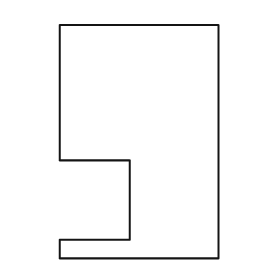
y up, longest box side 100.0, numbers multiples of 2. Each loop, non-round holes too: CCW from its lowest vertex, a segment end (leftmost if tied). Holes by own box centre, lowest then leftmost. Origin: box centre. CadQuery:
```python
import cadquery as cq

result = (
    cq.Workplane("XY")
    .moveTo(-34.0, -50.0)
    .lineTo(34.0, -50.0)
    .lineTo(34.0, 50.0)
    .lineTo(-34.0, 50.0)
    .lineTo(-34.0, -8.0)
    .lineTo(-4.0, -8.0)
    .lineTo(-4.0, -42.0)
    .lineTo(-34.0, -42.0)
    .close()
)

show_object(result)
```